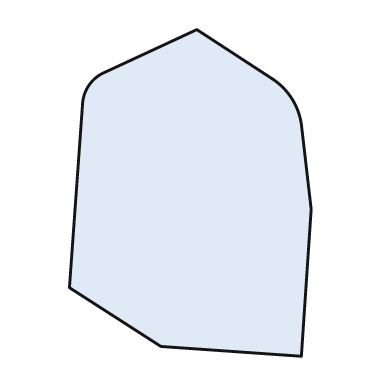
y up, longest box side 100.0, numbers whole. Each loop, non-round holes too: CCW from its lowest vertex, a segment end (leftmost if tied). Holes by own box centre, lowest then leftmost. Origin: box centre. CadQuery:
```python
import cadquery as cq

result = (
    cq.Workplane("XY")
    .moveTo(34.0, -50.0)
    .lineTo(37.0, -5.0)
    .lineTo(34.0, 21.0)
    .threePointArc((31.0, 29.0), (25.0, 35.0))
    .lineTo(2.0, 50.0)
    .lineTo(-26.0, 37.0)
    .threePointArc((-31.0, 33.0), (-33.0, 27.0))
    .lineTo(-37.0, -29.0)
    .lineTo(-9.0, -47.0)
    .close()
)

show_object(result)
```